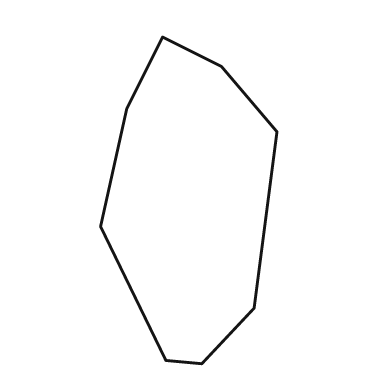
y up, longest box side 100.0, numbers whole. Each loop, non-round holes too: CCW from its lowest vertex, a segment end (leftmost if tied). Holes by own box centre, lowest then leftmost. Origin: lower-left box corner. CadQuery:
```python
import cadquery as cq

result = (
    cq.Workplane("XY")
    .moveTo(31.0, 0.0)
    .lineTo(47.0, 17.0)
    .lineTo(54.0, 71.0)
    .lineTo(37.0, 91.0)
    .lineTo(19.0, 100.0)
    .lineTo(8.0, 78.0)
    .lineTo(0.0, 42.0)
    .lineTo(20.0, 1.0)
    .close()
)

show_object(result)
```